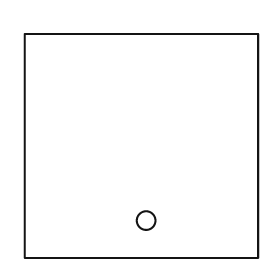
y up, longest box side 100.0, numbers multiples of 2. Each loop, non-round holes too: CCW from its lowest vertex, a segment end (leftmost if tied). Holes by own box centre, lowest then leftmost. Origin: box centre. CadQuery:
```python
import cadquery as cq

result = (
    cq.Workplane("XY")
    .moveTo(-50.0, -48.0)
    .lineTo(50.0, -48.0)
    .lineTo(50.0, 48.0)
    .lineTo(-50.0, 48.0)
    .close()
    .moveTo(2.0, -32.0)
    .circle(4.0)
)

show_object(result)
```